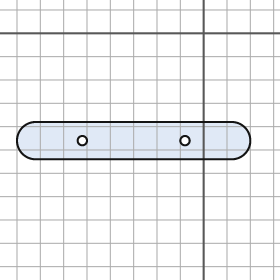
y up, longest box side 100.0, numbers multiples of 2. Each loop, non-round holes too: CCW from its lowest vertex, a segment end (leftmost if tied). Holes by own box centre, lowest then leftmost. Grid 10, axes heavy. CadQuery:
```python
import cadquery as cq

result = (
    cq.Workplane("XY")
    .moveTo(-72.0, -54.0)
    .lineTo(12.0, -54.0)
    .threePointArc((20.0, -46.0), (12.0, -38.0))
    .lineTo(-72.0, -38.0)
    .threePointArc((-80.0, -46.0), (-72.0, -54.0))
    .close()
    .moveTo(-52.0, -46.0)
    .circle(2.0)
    .moveTo(-8.0, -46.0)
    .circle(2.0)
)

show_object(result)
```